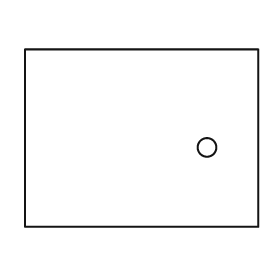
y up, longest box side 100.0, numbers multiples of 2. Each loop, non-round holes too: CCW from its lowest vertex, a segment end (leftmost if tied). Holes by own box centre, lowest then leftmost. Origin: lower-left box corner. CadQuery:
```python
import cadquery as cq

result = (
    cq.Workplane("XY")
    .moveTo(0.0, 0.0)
    .lineTo(100.0, 0.0)
    .lineTo(100.0, 76.0)
    .lineTo(0.0, 76.0)
    .close()
    .moveTo(78.0, 34.0)
    .circle(4.0)
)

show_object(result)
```